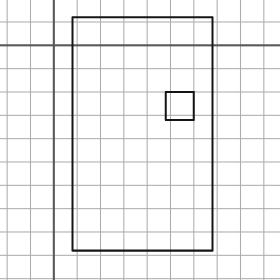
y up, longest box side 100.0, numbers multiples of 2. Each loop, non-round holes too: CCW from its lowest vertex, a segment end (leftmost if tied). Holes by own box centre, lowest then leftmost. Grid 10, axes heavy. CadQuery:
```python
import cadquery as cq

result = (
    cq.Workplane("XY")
    .moveTo(8.0, -88.0)
    .lineTo(68.0, -88.0)
    .lineTo(68.0, 12.0)
    .lineTo(8.0, 12.0)
    .close()
    .moveTo(48.0, -32.0)
    .lineTo(60.0, -32.0)
    .lineTo(60.0, -20.0)
    .lineTo(48.0, -20.0)
    .close()
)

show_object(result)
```